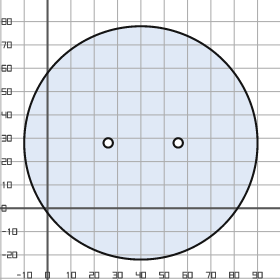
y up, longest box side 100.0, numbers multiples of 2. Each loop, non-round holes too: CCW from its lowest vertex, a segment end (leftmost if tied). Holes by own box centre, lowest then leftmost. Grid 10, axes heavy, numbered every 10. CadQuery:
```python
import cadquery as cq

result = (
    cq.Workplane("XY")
    .moveTo(40.0, 28.0)
    .circle(50.0)
    .moveTo(26.0, 28.0)
    .circle(2.0)
    .moveTo(56.0, 28.0)
    .circle(2.0)
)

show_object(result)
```